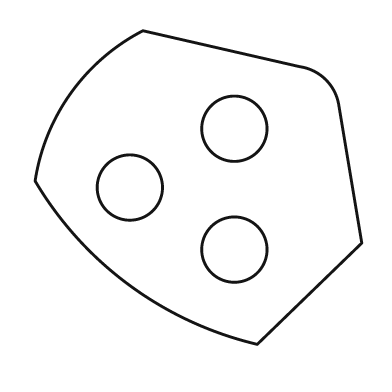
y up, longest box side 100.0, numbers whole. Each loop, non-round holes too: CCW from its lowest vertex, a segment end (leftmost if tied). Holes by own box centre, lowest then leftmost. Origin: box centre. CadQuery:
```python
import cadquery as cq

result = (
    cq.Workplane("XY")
    .moveTo(18.0, -48.0)
    .lineTo(50.0, -17.0)
    .lineTo(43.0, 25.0)
    .threePointArc((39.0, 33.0), (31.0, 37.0))
    .lineTo(-17.0, 48.0)
    .threePointArc((-39.0, 29.0), (-50.0, 2.0))
    .threePointArc((-21.0, -30.0), (18.0, -48.0))
    .close()
    .moveTo(11.0, -19.0)
    .circle(10.0)
    .moveTo(-21.0, 0.0)
    .circle(10.0)
    .moveTo(11.0, 18.0)
    .circle(10.0)
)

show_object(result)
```